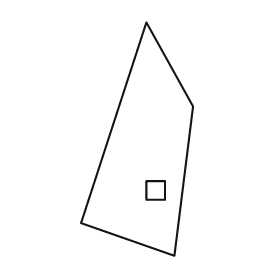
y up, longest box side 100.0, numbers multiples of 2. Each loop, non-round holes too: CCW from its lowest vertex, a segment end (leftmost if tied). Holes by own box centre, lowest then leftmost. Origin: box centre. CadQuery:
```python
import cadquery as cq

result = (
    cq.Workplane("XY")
    .moveTo(16.0, -50.0)
    .lineTo(24.0, 14.0)
    .lineTo(4.0, 50.0)
    .lineTo(-24.0, -36.0)
    .close()
    .moveTo(4.0, -26.0)
    .lineTo(12.0, -26.0)
    .lineTo(12.0, -18.0)
    .lineTo(4.0, -18.0)
    .close()
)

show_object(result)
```